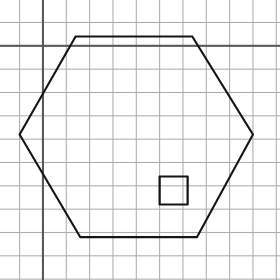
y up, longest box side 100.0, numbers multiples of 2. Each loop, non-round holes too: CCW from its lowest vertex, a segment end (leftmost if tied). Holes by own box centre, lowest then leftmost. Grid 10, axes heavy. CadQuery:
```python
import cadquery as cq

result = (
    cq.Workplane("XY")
    .moveTo(16.0, -82.0)
    .lineTo(66.0, -82.0)
    .lineTo(90.0, -38.0)
    .lineTo(64.0, 4.0)
    .lineTo(14.0, 4.0)
    .lineTo(-10.0, -38.0)
    .close()
    .moveTo(50.0, -68.0)
    .lineTo(62.0, -68.0)
    .lineTo(62.0, -56.0)
    .lineTo(50.0, -56.0)
    .close()
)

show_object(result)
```